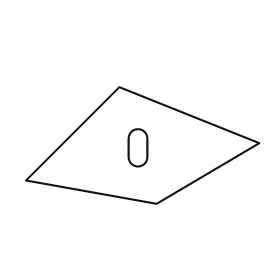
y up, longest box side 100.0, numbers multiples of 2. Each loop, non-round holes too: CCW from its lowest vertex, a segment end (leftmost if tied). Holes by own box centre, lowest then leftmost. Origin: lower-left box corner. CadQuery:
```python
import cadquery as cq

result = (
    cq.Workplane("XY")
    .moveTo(56.0, 0.0)
    .lineTo(100.0, 26.0)
    .lineTo(40.0, 50.0)
    .lineTo(0.0, 10.0)
    .close()
    .moveTo(44.0, 20.0)
    .threePointArc((48.0, 16.0), (52.0, 20.0))
    .lineTo(52.0, 28.0)
    .threePointArc((48.0, 32.0), (44.0, 28.0))
    .close()
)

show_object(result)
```